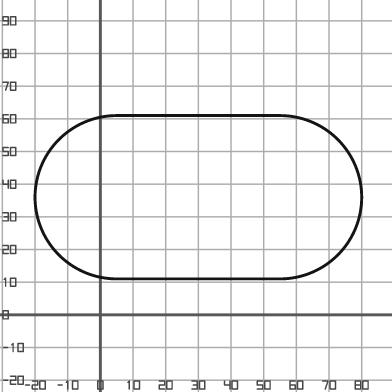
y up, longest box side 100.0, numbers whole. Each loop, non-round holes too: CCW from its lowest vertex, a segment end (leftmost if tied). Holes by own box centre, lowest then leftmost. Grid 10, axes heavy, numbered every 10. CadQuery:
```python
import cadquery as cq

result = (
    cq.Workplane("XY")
    .moveTo(5.0, 11.0)
    .lineTo(55.0, 11.0)
    .threePointArc((80.0, 36.0), (55.0, 61.0))
    .lineTo(5.0, 61.0)
    .threePointArc((-20.0, 36.0), (5.0, 11.0))
    .close()
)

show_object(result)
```